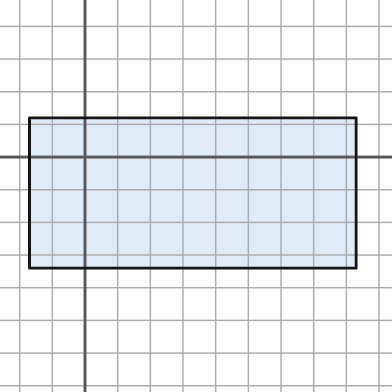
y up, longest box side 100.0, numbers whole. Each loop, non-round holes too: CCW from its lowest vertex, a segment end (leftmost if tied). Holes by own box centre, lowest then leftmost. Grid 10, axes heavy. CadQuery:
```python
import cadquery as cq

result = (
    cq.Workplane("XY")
    .moveTo(-17.0, -34.0)
    .lineTo(83.0, -34.0)
    .lineTo(83.0, 12.0)
    .lineTo(-17.0, 12.0)
    .close()
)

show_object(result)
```